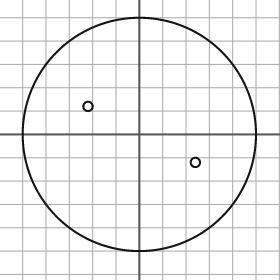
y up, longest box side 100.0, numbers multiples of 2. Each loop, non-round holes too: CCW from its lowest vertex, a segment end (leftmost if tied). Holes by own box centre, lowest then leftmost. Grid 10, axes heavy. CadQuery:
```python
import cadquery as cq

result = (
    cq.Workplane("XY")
    .moveTo(0.0, 0.0)
    .circle(50.0)
    .moveTo(24.0, -12.0)
    .circle(2.0)
    .moveTo(-22.0, 12.0)
    .circle(2.0)
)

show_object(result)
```